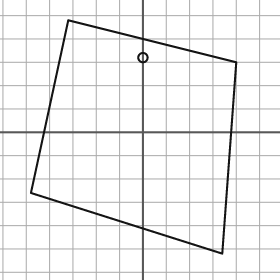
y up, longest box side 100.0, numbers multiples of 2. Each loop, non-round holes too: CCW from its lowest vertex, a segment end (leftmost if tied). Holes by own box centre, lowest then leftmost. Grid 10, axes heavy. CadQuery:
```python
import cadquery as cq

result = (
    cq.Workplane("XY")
    .moveTo(34.0, -52.0)
    .lineTo(40.0, 30.0)
    .lineTo(-32.0, 48.0)
    .lineTo(-48.0, -26.0)
    .close()
    .moveTo(0.0, 32.0)
    .circle(2.0)
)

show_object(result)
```